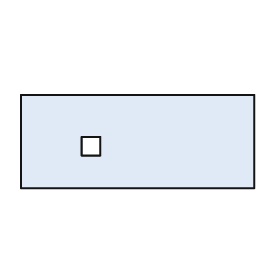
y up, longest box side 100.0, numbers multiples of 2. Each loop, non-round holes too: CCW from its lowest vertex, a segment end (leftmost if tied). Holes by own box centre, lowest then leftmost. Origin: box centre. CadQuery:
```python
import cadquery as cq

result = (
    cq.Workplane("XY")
    .moveTo(-50.0, -20.0)
    .lineTo(50.0, -20.0)
    .lineTo(50.0, 20.0)
    .lineTo(-50.0, 20.0)
    .close()
    .moveTo(-24.0, -6.0)
    .lineTo(-16.0, -6.0)
    .lineTo(-16.0, 2.0)
    .lineTo(-24.0, 2.0)
    .close()
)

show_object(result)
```